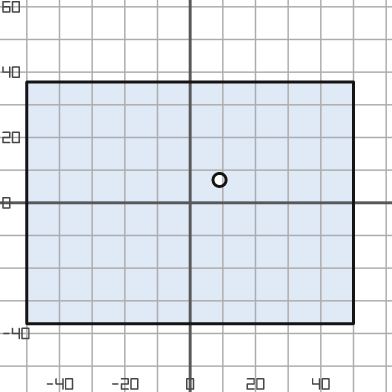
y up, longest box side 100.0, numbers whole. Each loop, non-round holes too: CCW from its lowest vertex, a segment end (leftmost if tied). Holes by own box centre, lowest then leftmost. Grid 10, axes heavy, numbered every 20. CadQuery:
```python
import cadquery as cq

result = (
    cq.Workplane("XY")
    .moveTo(-50.0, -37.0)
    .lineTo(50.0, -37.0)
    .lineTo(50.0, 37.0)
    .lineTo(-50.0, 37.0)
    .close()
    .moveTo(9.0, 7.0)
    .circle(2.0)
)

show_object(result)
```